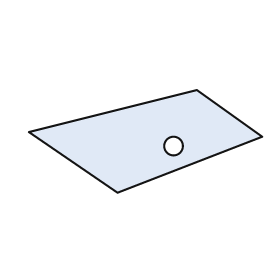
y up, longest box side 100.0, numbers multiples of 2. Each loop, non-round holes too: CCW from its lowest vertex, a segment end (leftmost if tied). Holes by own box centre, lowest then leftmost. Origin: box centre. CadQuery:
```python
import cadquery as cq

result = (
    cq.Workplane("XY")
    .moveTo(-12.0, -22.0)
    .lineTo(50.0, 2.0)
    .lineTo(22.0, 22.0)
    .lineTo(-50.0, 4.0)
    .close()
    .moveTo(12.0, -2.0)
    .circle(4.0)
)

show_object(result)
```